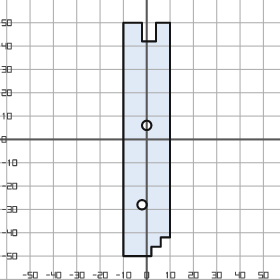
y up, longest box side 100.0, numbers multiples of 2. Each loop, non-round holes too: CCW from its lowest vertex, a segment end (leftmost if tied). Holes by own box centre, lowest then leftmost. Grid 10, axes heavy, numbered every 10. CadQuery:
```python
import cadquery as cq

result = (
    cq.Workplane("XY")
    .moveTo(-10.0, -50.0)
    .lineTo(2.0, -50.0)
    .lineTo(2.0, -46.0)
    .lineTo(6.0, -46.0)
    .lineTo(6.0, -42.0)
    .lineTo(10.0, -42.0)
    .lineTo(10.0, 50.0)
    .lineTo(4.0, 50.0)
    .lineTo(4.0, 42.0)
    .lineTo(-2.0, 42.0)
    .lineTo(-2.0, 50.0)
    .lineTo(-10.0, 50.0)
    .close()
    .moveTo(-2.0, -28.0)
    .circle(2.0)
    .moveTo(0.0, 6.0)
    .circle(2.0)
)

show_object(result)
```